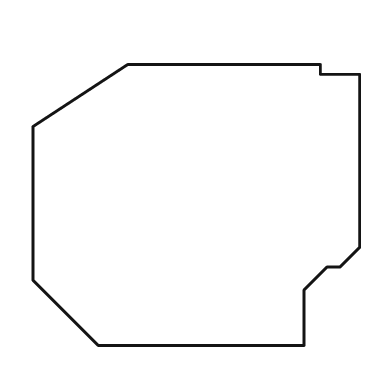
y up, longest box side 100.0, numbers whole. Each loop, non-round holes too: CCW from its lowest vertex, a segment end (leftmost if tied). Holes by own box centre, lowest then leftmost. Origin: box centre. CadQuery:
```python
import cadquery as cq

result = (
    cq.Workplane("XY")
    .moveTo(-30.0, -43.0)
    .lineTo(33.0, -43.0)
    .lineTo(33.0, -26.0)
    .lineTo(40.0, -19.0)
    .lineTo(44.0, -19.0)
    .lineTo(50.0, -13.0)
    .lineTo(50.0, 40.0)
    .lineTo(38.0, 40.0)
    .lineTo(38.0, 43.0)
    .lineTo(-21.0, 43.0)
    .lineTo(-50.0, 24.0)
    .lineTo(-50.0, -23.0)
    .close()
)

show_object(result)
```